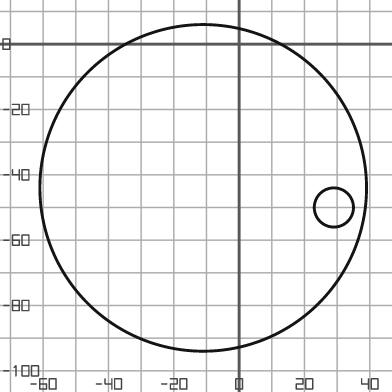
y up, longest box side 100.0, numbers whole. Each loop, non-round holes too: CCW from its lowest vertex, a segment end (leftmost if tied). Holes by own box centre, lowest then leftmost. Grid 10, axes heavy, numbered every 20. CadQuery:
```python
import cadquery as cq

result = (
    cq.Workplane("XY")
    .moveTo(-11.0, -44.0)
    .circle(50.0)
    .moveTo(29.0, -50.0)
    .circle(6.0)
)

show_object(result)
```